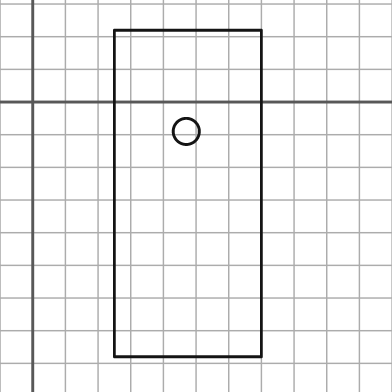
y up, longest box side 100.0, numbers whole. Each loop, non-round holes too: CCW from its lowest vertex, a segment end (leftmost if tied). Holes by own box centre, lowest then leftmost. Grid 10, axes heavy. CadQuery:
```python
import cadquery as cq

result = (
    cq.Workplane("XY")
    .moveTo(25.0, -78.0)
    .lineTo(70.0, -78.0)
    .lineTo(70.0, 22.0)
    .lineTo(25.0, 22.0)
    .close()
    .moveTo(47.0, -9.0)
    .circle(4.0)
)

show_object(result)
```